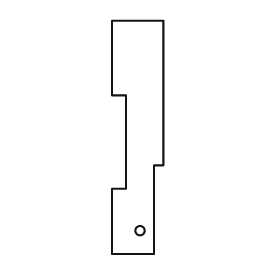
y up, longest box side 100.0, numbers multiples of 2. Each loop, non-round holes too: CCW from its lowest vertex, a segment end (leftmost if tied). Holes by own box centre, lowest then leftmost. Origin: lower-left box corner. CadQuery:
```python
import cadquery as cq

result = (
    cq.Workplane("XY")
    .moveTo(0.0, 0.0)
    .lineTo(18.0, 0.0)
    .lineTo(18.0, 38.0)
    .lineTo(22.0, 38.0)
    .lineTo(22.0, 100.0)
    .lineTo(0.0, 100.0)
    .lineTo(0.0, 68.0)
    .lineTo(6.0, 68.0)
    .lineTo(6.0, 28.0)
    .lineTo(0.0, 28.0)
    .close()
    .moveTo(12.0, 10.0)
    .circle(2.0)
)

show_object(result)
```